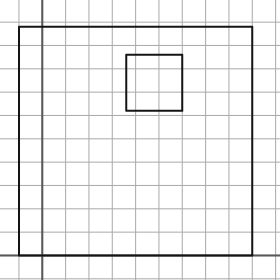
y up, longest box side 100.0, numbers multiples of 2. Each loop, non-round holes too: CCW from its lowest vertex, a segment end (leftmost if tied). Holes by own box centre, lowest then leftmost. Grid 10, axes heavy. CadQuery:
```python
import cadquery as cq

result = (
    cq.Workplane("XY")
    .moveTo(-10.0, 0.0)
    .lineTo(90.0, 0.0)
    .lineTo(90.0, 98.0)
    .lineTo(-10.0, 98.0)
    .close()
    .moveTo(36.0, 62.0)
    .lineTo(60.0, 62.0)
    .lineTo(60.0, 86.0)
    .lineTo(36.0, 86.0)
    .close()
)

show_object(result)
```